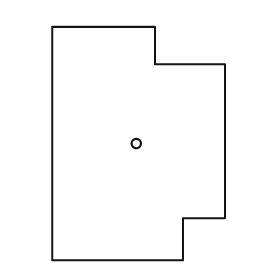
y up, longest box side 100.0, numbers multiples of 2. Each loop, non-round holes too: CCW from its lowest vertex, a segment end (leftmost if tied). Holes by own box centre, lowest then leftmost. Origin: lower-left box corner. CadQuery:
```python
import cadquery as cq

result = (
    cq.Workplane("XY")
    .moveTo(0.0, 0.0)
    .lineTo(56.0, 0.0)
    .lineTo(56.0, 18.0)
    .lineTo(74.0, 18.0)
    .lineTo(74.0, 84.0)
    .lineTo(44.0, 84.0)
    .lineTo(44.0, 100.0)
    .lineTo(0.0, 100.0)
    .close()
    .moveTo(36.0, 50.0)
    .circle(2.0)
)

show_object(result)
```